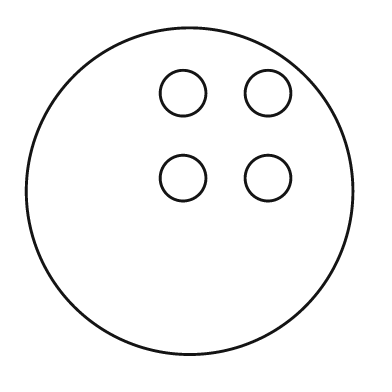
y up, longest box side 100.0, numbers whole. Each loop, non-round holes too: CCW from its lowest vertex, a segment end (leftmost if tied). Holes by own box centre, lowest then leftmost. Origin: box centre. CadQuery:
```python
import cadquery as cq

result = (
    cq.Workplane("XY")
    .moveTo(0.0, 0.0)
    .circle(50.0)
    .moveTo(-2.0, 4.0)
    .circle(7.0)
    .moveTo(24.0, 4.0)
    .circle(7.0)
    .moveTo(-2.0, 30.0)
    .circle(7.0)
    .moveTo(24.0, 30.0)
    .circle(7.0)
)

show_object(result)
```